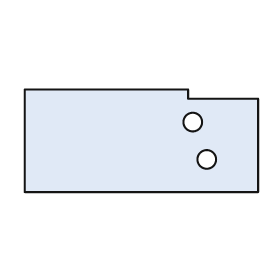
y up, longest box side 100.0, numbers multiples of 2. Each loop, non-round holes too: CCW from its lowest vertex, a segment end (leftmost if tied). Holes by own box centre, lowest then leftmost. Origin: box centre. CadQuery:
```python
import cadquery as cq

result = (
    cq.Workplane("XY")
    .moveTo(-50.0, -22.0)
    .lineTo(50.0, -22.0)
    .lineTo(50.0, 18.0)
    .lineTo(20.0, 18.0)
    .lineTo(20.0, 22.0)
    .lineTo(-50.0, 22.0)
    .close()
    .moveTo(28.0, -8.0)
    .circle(4.0)
    .moveTo(22.0, 8.0)
    .circle(4.0)
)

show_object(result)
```